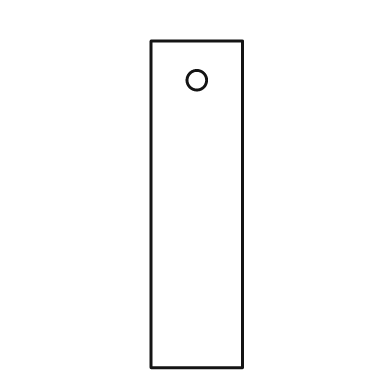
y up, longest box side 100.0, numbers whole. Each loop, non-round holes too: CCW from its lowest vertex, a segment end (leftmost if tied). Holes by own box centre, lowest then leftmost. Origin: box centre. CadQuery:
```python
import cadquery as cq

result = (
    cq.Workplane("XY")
    .moveTo(-14.0, -50.0)
    .lineTo(14.0, -50.0)
    .lineTo(14.0, 50.0)
    .lineTo(-14.0, 50.0)
    .close()
    .moveTo(0.0, 38.0)
    .circle(3.0)
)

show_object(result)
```